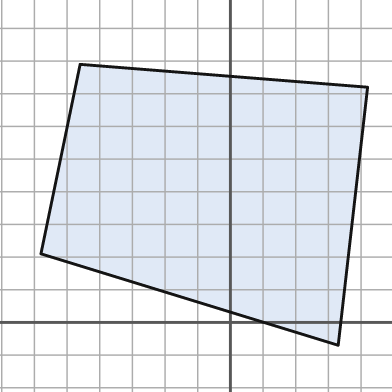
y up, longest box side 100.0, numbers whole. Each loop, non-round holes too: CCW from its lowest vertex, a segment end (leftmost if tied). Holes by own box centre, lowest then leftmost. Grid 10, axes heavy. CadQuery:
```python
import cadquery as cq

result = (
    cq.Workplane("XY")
    .moveTo(33.0, -7.0)
    .lineTo(42.0, 72.0)
    .lineTo(-46.0, 79.0)
    .lineTo(-58.0, 21.0)
    .close()
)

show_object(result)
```